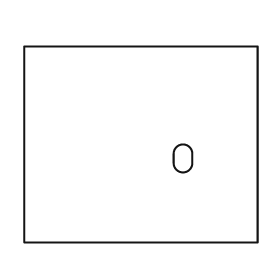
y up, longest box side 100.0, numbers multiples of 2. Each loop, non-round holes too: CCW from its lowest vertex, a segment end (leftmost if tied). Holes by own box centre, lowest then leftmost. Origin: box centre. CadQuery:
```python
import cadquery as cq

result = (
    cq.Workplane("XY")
    .moveTo(-50.0, -42.0)
    .lineTo(50.0, -42.0)
    .lineTo(50.0, 42.0)
    .lineTo(-50.0, 42.0)
    .close()
    .moveTo(14.0, -8.0)
    .threePointArc((18.0, -12.0), (22.0, -8.0))
    .lineTo(22.0, -4.0)
    .threePointArc((18.0, 0.0), (14.0, -4.0))
    .close()
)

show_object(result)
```